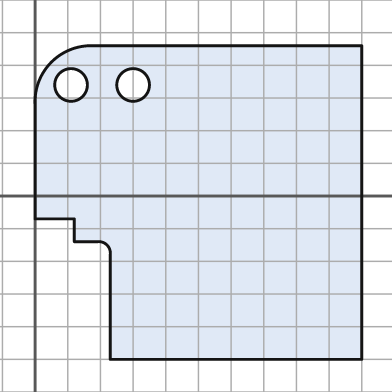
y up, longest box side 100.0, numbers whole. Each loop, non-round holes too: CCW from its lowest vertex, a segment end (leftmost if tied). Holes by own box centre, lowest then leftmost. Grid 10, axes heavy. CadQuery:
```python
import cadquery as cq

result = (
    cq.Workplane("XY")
    .moveTo(23.0, -50.0)
    .lineTo(100.0, -50.0)
    .lineTo(100.0, 46.0)
    .lineTo(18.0, 46.0)
    .threePointArc((5.0, 41.0), (0.0, 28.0))
    .lineTo(0.0, -7.0)
    .lineTo(12.0, -7.0)
    .lineTo(12.0, -14.0)
    .lineTo(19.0, -14.0)
    .threePointArc((22.0, -15.0), (23.0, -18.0))
    .close()
    .moveTo(11.0, 34.0)
    .circle(5.0)
    .moveTo(30.0, 34.0)
    .circle(5.0)
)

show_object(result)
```